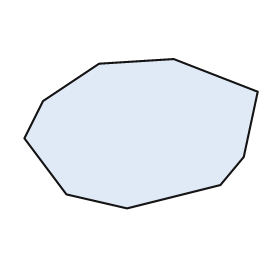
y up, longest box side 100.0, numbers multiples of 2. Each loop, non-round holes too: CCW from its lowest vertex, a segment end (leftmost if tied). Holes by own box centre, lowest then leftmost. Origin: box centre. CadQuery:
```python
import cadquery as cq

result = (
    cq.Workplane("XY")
    .moveTo(-6.0, -32.0)
    .lineTo(34.0, -22.0)
    .lineTo(44.0, -10.0)
    .lineTo(50.0, 18.0)
    .lineTo(14.0, 32.0)
    .lineTo(-18.0, 30.0)
    .lineTo(-42.0, 14.0)
    .lineTo(-50.0, -2.0)
    .lineTo(-32.0, -26.0)
    .close()
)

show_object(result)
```